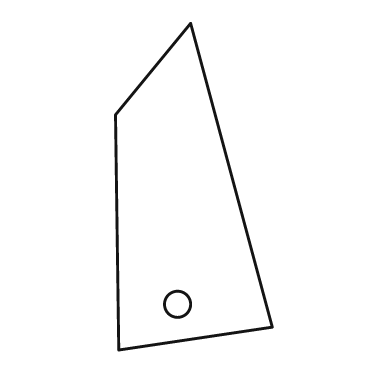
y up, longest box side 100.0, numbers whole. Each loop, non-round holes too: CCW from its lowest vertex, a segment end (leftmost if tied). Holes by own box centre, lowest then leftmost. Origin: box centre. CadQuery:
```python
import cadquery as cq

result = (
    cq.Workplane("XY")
    .moveTo(-23.0, -50.0)
    .lineTo(24.0, -43.0)
    .lineTo(-1.0, 50.0)
    .lineTo(-24.0, 22.0)
    .close()
    .moveTo(-5.0, -36.0)
    .circle(4.0)
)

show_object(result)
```